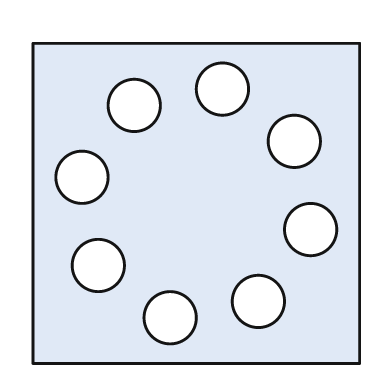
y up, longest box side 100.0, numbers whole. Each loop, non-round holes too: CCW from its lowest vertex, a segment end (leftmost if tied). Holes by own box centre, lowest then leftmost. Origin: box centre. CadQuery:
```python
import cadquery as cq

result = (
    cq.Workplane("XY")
    .moveTo(-50.0, -49.0)
    .lineTo(50.0, -49.0)
    .lineTo(50.0, 49.0)
    .lineTo(-50.0, 49.0)
    .close()
    .moveTo(-8.0, -35.0)
    .circle(8.0)
    .moveTo(19.0, -30.0)
    .circle(8.0)
    .moveTo(-30.0, -19.0)
    .circle(8.0)
    .moveTo(35.0, -8.0)
    .circle(8.0)
    .moveTo(-35.0, 8.0)
    .circle(8.0)
    .moveTo(30.0, 19.0)
    .circle(8.0)
    .moveTo(-19.0, 30.0)
    .circle(8.0)
    .moveTo(8.0, 35.0)
    .circle(8.0)
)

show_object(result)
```